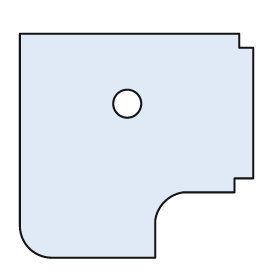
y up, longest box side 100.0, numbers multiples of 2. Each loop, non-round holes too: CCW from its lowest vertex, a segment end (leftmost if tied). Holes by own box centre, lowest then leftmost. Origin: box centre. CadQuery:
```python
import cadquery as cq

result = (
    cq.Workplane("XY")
    .moveTo(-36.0, -48.0)
    .lineTo(8.0, -48.0)
    .lineTo(8.0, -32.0)
    .threePointArc((12.0, -24.0), (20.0, -20.0))
    .lineTo(42.0, -20.0)
    .lineTo(42.0, -14.0)
    .lineTo(50.0, -14.0)
    .lineTo(50.0, 42.0)
    .lineTo(44.0, 42.0)
    .lineTo(44.0, 48.0)
    .lineTo(-50.0, 48.0)
    .lineTo(-50.0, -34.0)
    .threePointArc((-46.0, -44.0), (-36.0, -48.0))
    .close()
    .moveTo(-4.0, 18.0)
    .circle(6.0)
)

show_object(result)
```